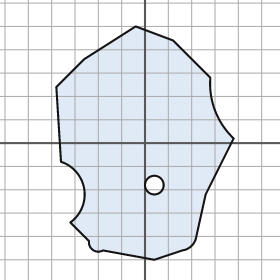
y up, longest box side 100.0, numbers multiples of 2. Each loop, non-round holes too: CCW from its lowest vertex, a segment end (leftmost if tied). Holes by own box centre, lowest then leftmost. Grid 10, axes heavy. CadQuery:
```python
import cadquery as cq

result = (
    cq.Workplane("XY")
    .moveTo(4.0, -50.0)
    .lineTo(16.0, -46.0)
    .threePointArc((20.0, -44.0), (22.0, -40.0))
    .lineTo(26.0, -22.0)
    .lineTo(38.0, 2.0)
    .threePointArc((30.0, 14.0), (28.0, 28.0))
    .lineTo(12.0, 44.0)
    .lineTo(-4.0, 50.0)
    .lineTo(-26.0, 36.0)
    .lineTo(-38.0, 24.0)
    .lineTo(-36.0, -8.0)
    .threePointArc((-26.0, -20.0), (-32.0, -34.0))
    .lineTo(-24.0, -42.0)
    .threePointArc((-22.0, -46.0), (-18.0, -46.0))
    .close()
    .moveTo(4.0, -18.0)
    .circle(4.0)
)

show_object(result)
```